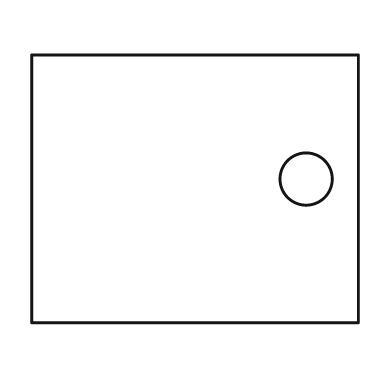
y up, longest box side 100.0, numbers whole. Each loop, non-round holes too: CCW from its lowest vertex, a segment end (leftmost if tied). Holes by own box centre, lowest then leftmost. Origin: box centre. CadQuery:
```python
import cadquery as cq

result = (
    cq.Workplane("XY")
    .moveTo(-50.0, -41.0)
    .lineTo(50.0, -41.0)
    .lineTo(50.0, 41.0)
    .lineTo(-50.0, 41.0)
    .close()
    .moveTo(34.0, 3.0)
    .circle(8.0)
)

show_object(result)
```